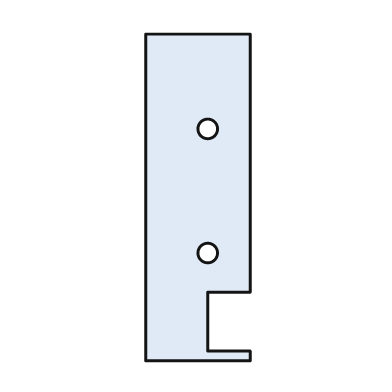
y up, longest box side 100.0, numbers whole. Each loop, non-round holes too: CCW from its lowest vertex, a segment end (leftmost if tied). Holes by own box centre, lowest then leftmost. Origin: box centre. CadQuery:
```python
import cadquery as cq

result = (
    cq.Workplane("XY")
    .moveTo(-16.0, -50.0)
    .lineTo(16.0, -50.0)
    .lineTo(16.0, -47.0)
    .lineTo(3.0, -47.0)
    .lineTo(3.0, -29.0)
    .lineTo(16.0, -29.0)
    .lineTo(16.0, 50.0)
    .lineTo(-16.0, 50.0)
    .close()
    .moveTo(3.0, -17.0)
    .circle(3.0)
    .moveTo(3.0, 21.0)
    .circle(3.0)
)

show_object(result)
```